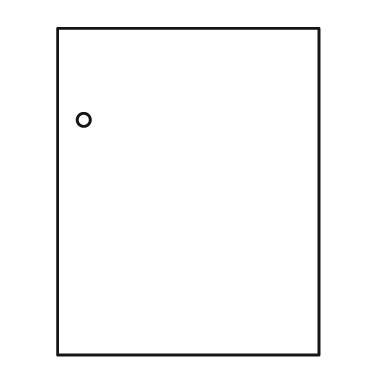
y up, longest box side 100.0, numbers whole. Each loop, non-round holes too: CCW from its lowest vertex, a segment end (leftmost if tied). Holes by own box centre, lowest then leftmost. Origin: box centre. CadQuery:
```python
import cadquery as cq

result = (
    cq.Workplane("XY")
    .moveTo(-40.0, -50.0)
    .lineTo(40.0, -50.0)
    .lineTo(40.0, 50.0)
    .lineTo(-40.0, 50.0)
    .close()
    .moveTo(-32.0, 22.0)
    .circle(2.0)
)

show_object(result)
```